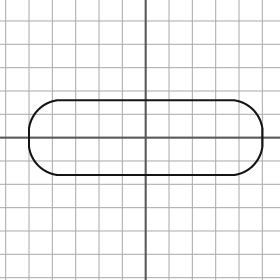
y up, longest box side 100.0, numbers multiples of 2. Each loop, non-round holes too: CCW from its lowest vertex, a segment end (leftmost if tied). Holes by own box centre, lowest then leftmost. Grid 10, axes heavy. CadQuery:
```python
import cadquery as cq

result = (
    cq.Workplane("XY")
    .moveTo(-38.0, -16.0)
    .lineTo(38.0, -16.0)
    .threePointArc((46.0, -12.0), (50.0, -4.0))
    .lineTo(50.0, 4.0)
    .threePointArc((46.0, 12.0), (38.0, 16.0))
    .lineTo(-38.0, 16.0)
    .threePointArc((-46.0, 12.0), (-50.0, 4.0))
    .lineTo(-50.0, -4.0)
    .threePointArc((-46.0, -12.0), (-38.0, -16.0))
    .close()
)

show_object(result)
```